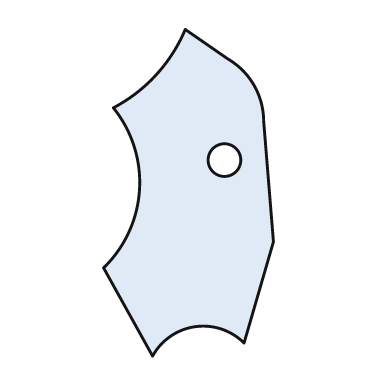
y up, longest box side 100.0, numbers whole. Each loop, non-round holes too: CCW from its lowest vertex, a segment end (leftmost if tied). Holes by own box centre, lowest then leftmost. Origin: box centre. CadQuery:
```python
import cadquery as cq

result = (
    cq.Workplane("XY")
    .moveTo(-11.0, -50.0)
    .threePointArc((2.0, -41.0), (17.0, -46.0))
    .lineTo(26.0, -15.0)
    .lineTo(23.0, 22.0)
    .threePointArc((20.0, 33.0), (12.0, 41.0))
    .lineTo(-1.0, 50.0)
    .threePointArc((-10.0, 36.0), (-23.0, 26.0))
    .threePointArc((-15.0, 1.0), (-26.0, -23.0))
    .close()
    .moveTo(11.0, 10.0)
    .circle(5.0)
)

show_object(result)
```